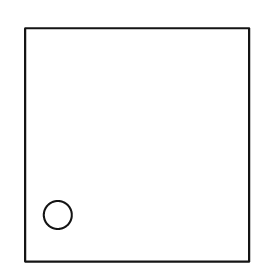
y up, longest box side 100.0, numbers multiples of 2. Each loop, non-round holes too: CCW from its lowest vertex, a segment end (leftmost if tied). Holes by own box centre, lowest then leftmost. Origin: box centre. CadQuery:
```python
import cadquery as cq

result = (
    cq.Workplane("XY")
    .moveTo(-48.0, -50.0)
    .lineTo(48.0, -50.0)
    .lineTo(48.0, 50.0)
    .lineTo(-48.0, 50.0)
    .close()
    .moveTo(-34.0, -30.0)
    .circle(6.0)
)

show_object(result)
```